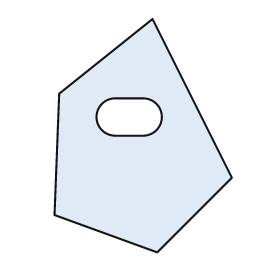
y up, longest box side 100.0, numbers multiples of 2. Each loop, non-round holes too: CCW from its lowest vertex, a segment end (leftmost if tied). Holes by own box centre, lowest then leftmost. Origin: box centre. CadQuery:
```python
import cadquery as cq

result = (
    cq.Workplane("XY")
    .moveTo(6.0, -50.0)
    .lineTo(38.0, -18.0)
    .lineTo(4.0, 50.0)
    .lineTo(-36.0, 18.0)
    .lineTo(-38.0, -34.0)
    .close()
    .moveTo(-12.0, 0.0)
    .lineTo(0.0, 0.0)
    .threePointArc((8.0, 8.0), (0.0, 16.0))
    .lineTo(-12.0, 16.0)
    .threePointArc((-20.0, 8.0), (-12.0, 0.0))
    .close()
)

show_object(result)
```